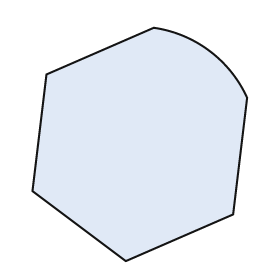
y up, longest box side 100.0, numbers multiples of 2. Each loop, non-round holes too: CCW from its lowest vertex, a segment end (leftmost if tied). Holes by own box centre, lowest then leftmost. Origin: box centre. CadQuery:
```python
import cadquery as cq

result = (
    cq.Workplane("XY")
    .moveTo(-6.0, -50.0)
    .lineTo(40.0, -30.0)
    .lineTo(46.0, 20.0)
    .threePointArc((30.0, 40.0), (6.0, 50.0))
    .lineTo(-40.0, 30.0)
    .lineTo(-46.0, -20.0)
    .close()
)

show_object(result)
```